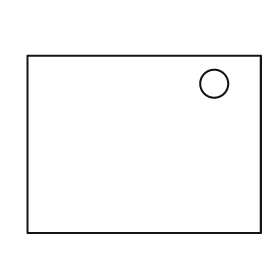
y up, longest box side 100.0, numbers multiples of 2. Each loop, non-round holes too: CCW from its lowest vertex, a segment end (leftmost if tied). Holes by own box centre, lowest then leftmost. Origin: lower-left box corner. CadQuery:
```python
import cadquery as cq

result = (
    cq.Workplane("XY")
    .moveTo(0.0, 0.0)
    .lineTo(100.0, 0.0)
    .lineTo(100.0, 76.0)
    .lineTo(0.0, 76.0)
    .close()
    .moveTo(80.0, 64.0)
    .circle(6.0)
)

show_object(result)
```